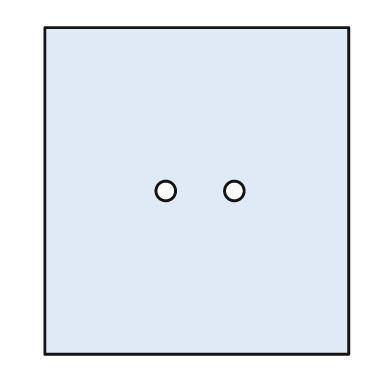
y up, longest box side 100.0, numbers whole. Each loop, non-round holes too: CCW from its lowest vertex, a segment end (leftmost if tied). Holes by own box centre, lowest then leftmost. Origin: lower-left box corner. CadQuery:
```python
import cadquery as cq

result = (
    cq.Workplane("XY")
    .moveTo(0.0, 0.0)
    .lineTo(93.0, 0.0)
    .lineTo(93.0, 100.0)
    .lineTo(0.0, 100.0)
    .close()
    .moveTo(37.0, 50.0)
    .circle(3.0)
    .moveTo(58.0, 50.0)
    .circle(3.0)
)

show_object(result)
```